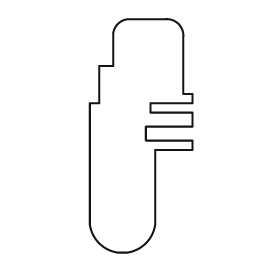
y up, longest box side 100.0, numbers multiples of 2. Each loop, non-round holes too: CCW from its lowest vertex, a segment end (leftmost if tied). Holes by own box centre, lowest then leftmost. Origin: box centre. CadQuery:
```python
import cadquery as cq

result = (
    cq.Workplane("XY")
    .moveTo(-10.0, -50.0)
    .lineTo(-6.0, -50.0)
    .threePointArc((2.0, -46.0), (6.0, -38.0))
    .lineTo(6.0, -6.0)
    .lineTo(22.0, -6.0)
    .lineTo(22.0, -2.0)
    .lineTo(2.0, -2.0)
    .lineTo(2.0, 4.0)
    .lineTo(22.0, 4.0)
    .lineTo(22.0, 10.0)
    .lineTo(4.0, 10.0)
    .lineTo(4.0, 14.0)
    .lineTo(22.0, 14.0)
    .lineTo(22.0, 18.0)
    .lineTo(18.0, 18.0)
    .lineTo(18.0, 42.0)
    .threePointArc((16.0, 48.0), (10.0, 50.0))
    .lineTo(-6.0, 50.0)
    .threePointArc((-10.0, 48.0), (-12.0, 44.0))
    .lineTo(-12.0, 30.0)
    .lineTo(-18.0, 30.0)
    .lineTo(-18.0, 14.0)
    .lineTo(-22.0, 14.0)
    .lineTo(-22.0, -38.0)
    .threePointArc((-18.0, -46.0), (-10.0, -50.0))
    .close()
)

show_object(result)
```